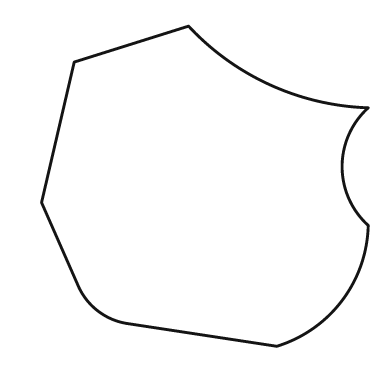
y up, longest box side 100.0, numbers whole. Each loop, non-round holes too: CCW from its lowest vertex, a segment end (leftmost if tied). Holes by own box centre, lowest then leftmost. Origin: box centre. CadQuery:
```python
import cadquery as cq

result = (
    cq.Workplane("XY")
    .moveTo(22.0, -49.0)
    .threePointArc((42.0, -35.0), (50.0, -12.0))
    .threePointArc((42.0, 6.0), (50.0, 24.0))
    .threePointArc((20.0, 31.0), (-5.0, 49.0))
    .lineTo(-40.0, 38.0)
    .lineTo(-50.0, -5.0)
    .lineTo(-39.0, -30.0)
    .threePointArc((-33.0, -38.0), (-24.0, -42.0))
    .close()
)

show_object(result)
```